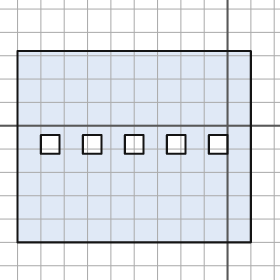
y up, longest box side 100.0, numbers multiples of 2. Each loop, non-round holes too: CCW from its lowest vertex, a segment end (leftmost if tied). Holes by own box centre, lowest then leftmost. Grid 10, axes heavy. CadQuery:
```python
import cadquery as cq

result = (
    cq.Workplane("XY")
    .moveTo(-90.0, -50.0)
    .lineTo(10.0, -50.0)
    .lineTo(10.0, 32.0)
    .lineTo(-90.0, 32.0)
    .close()
    .moveTo(-80.0, -12.0)
    .lineTo(-72.0, -12.0)
    .lineTo(-72.0, -4.0)
    .lineTo(-80.0, -4.0)
    .close()
    .moveTo(-62.0, -12.0)
    .lineTo(-54.0, -12.0)
    .lineTo(-54.0, -4.0)
    .lineTo(-62.0, -4.0)
    .close()
    .moveTo(-44.0, -12.0)
    .lineTo(-36.0, -12.0)
    .lineTo(-36.0, -4.0)
    .lineTo(-44.0, -4.0)
    .close()
    .moveTo(-26.0, -12.0)
    .lineTo(-18.0, -12.0)
    .lineTo(-18.0, -4.0)
    .lineTo(-26.0, -4.0)
    .close()
    .moveTo(-8.0, -12.0)
    .lineTo(0.0, -12.0)
    .lineTo(0.0, -4.0)
    .lineTo(-8.0, -4.0)
    .close()
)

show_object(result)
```